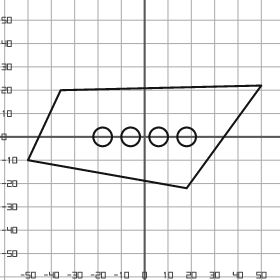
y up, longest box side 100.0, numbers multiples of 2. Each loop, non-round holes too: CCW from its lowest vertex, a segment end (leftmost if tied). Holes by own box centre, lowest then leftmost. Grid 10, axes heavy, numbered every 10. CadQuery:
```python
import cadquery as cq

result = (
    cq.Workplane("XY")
    .moveTo(18.0, -22.0)
    .lineTo(50.0, 22.0)
    .lineTo(-36.0, 20.0)
    .lineTo(-50.0, -10.0)
    .close()
    .moveTo(-18.0, 0.0)
    .circle(4.0)
    .moveTo(-6.0, 0.0)
    .circle(4.0)
    .moveTo(6.0, 0.0)
    .circle(4.0)
    .moveTo(18.0, 0.0)
    .circle(4.0)
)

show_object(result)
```